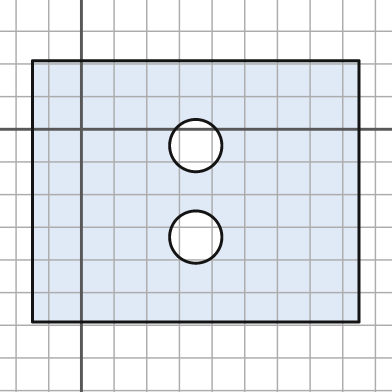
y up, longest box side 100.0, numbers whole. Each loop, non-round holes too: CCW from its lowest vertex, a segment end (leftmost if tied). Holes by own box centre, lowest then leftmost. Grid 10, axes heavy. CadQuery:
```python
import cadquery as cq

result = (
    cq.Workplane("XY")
    .moveTo(-15.0, -59.0)
    .lineTo(85.0, -59.0)
    .lineTo(85.0, 21.0)
    .lineTo(-15.0, 21.0)
    .close()
    .moveTo(35.0, -33.0)
    .circle(8.0)
    .moveTo(35.0, -5.0)
    .circle(8.0)
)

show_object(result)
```